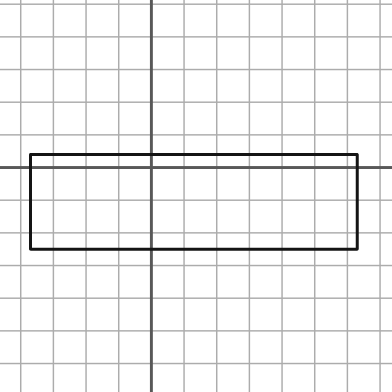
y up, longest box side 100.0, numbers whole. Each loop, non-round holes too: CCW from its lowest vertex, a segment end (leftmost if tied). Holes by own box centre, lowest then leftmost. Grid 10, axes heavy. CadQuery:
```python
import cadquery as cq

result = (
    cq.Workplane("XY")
    .moveTo(-37.0, -25.0)
    .lineTo(63.0, -25.0)
    .lineTo(63.0, 4.0)
    .lineTo(-37.0, 4.0)
    .close()
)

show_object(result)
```